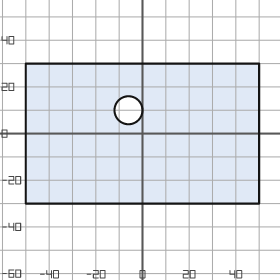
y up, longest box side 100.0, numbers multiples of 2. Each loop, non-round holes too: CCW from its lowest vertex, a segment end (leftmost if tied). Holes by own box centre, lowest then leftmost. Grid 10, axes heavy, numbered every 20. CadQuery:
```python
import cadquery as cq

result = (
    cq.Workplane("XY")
    .moveTo(-50.0, -30.0)
    .lineTo(50.0, -30.0)
    .lineTo(50.0, 30.0)
    .lineTo(-50.0, 30.0)
    .close()
    .moveTo(-6.0, 10.0)
    .circle(6.0)
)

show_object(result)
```